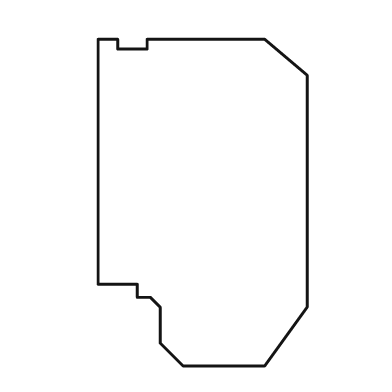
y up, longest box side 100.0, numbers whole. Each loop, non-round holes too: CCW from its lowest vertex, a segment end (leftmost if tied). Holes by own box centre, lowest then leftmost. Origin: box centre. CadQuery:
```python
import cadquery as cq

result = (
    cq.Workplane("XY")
    .moveTo(-6.0, -50.0)
    .lineTo(19.0, -50.0)
    .lineTo(32.0, -32.0)
    .lineTo(32.0, 39.0)
    .lineTo(19.0, 50.0)
    .lineTo(-17.0, 50.0)
    .lineTo(-17.0, 47.0)
    .lineTo(-26.0, 47.0)
    .lineTo(-26.0, 50.0)
    .lineTo(-32.0, 50.0)
    .lineTo(-32.0, -25.0)
    .lineTo(-20.0, -25.0)
    .lineTo(-20.0, -29.0)
    .lineTo(-16.0, -29.0)
    .lineTo(-13.0, -32.0)
    .lineTo(-13.0, -43.0)
    .close()
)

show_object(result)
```